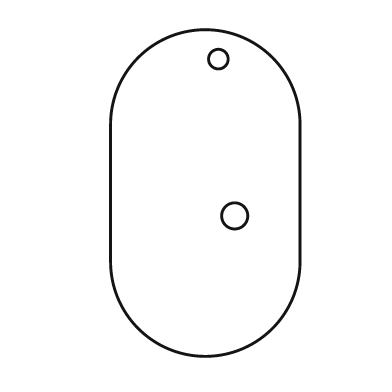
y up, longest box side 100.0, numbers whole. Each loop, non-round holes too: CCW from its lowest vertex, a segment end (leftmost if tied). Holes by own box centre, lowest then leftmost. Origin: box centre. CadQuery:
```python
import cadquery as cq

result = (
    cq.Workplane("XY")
    .moveTo(-29.0, -21.0)
    .threePointArc((0.0, -50.0), (29.0, -21.0))
    .lineTo(29.0, 21.0)
    .threePointArc((0.0, 50.0), (-29.0, 21.0))
    .close()
    .moveTo(9.0, -7.0)
    .circle(4.0)
    .moveTo(4.0, 41.0)
    .circle(3.0)
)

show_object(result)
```